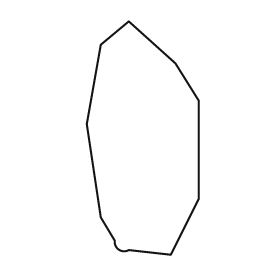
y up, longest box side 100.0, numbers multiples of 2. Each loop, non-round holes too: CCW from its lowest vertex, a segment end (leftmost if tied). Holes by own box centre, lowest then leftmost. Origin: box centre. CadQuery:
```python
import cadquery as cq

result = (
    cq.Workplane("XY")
    .moveTo(12.0, -50.0)
    .lineTo(24.0, -26.0)
    .lineTo(24.0, 16.0)
    .lineTo(14.0, 32.0)
    .lineTo(-6.0, 50.0)
    .lineTo(-18.0, 40.0)
    .lineTo(-24.0, 6.0)
    .lineTo(-18.0, -34.0)
    .lineTo(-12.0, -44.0)
    .threePointArc((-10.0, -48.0), (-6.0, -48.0))
    .close()
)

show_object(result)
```